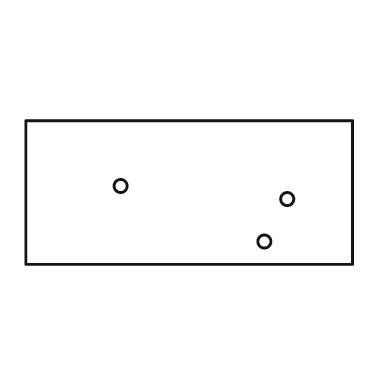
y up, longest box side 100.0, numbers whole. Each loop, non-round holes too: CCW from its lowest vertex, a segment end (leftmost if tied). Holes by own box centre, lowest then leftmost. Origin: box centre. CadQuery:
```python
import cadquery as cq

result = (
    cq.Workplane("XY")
    .moveTo(-50.0, -22.0)
    .lineTo(50.0, -22.0)
    .lineTo(50.0, 22.0)
    .lineTo(-50.0, 22.0)
    .close()
    .moveTo(23.0, -15.0)
    .circle(2.0)
    .moveTo(30.0, -2.0)
    .circle(2.0)
    .moveTo(-21.0, 2.0)
    .circle(2.0)
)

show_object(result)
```